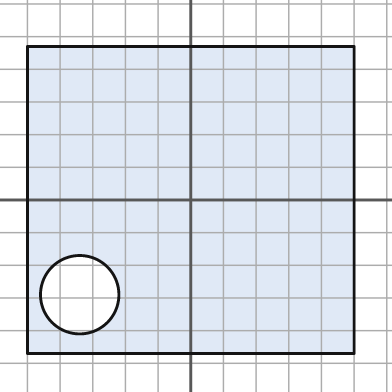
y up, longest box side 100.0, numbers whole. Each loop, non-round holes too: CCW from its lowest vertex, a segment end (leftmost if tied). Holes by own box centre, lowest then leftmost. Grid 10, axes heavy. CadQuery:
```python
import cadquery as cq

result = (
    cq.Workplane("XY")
    .moveTo(-50.0, -47.0)
    .lineTo(50.0, -47.0)
    .lineTo(50.0, 47.0)
    .lineTo(-50.0, 47.0)
    .close()
    .moveTo(-34.0, -29.0)
    .circle(12.0)
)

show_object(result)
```